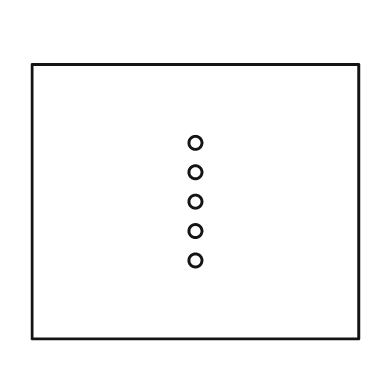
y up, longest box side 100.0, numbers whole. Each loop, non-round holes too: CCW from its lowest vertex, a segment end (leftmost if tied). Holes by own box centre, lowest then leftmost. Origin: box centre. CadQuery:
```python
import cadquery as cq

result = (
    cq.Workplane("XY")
    .moveTo(-50.0, -42.0)
    .lineTo(50.0, -42.0)
    .lineTo(50.0, 42.0)
    .lineTo(-50.0, 42.0)
    .close()
    .moveTo(0.0, -18.0)
    .circle(2.0)
    .moveTo(0.0, -9.0)
    .circle(2.0)
    .moveTo(0.0, 0.0)
    .circle(2.0)
    .moveTo(0.0, 9.0)
    .circle(2.0)
    .moveTo(0.0, 18.0)
    .circle(2.0)
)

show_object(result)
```